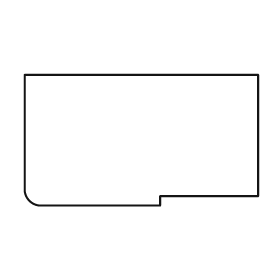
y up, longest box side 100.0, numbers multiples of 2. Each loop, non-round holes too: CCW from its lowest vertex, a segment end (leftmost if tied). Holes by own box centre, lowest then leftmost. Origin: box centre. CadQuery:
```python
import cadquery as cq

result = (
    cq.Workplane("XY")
    .moveTo(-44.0, -28.0)
    .lineTo(8.0, -28.0)
    .lineTo(8.0, -24.0)
    .lineTo(50.0, -24.0)
    .lineTo(50.0, 28.0)
    .lineTo(-50.0, 28.0)
    .lineTo(-50.0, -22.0)
    .threePointArc((-48.0, -26.0), (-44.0, -28.0))
    .close()
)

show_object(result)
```